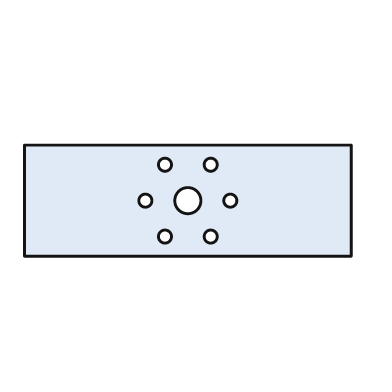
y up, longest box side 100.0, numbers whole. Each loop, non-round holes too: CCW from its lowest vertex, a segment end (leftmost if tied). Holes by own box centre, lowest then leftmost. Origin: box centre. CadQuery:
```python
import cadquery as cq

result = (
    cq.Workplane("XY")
    .moveTo(-50.0, -17.0)
    .lineTo(50.0, -17.0)
    .lineTo(50.0, 17.0)
    .lineTo(-50.0, 17.0)
    .close()
    .moveTo(-7.0, -11.0)
    .circle(2.0)
    .moveTo(7.0, -11.0)
    .circle(2.0)
    .moveTo(-13.0, 0.0)
    .circle(2.0)
    .moveTo(0.0, 0.0)
    .circle(4.0)
    .moveTo(13.0, 0.0)
    .circle(2.0)
    .moveTo(-7.0, 11.0)
    .circle(2.0)
    .moveTo(7.0, 11.0)
    .circle(2.0)
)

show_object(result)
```